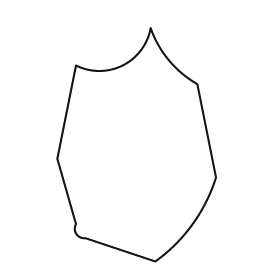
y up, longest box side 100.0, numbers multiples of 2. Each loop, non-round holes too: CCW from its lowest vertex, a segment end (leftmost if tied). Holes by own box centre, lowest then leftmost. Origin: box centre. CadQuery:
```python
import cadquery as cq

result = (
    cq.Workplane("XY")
    .moveTo(8.0, -50.0)
    .threePointArc((24.0, -34.0), (34.0, -14.0))
    .lineTo(26.0, 26.0)
    .threePointArc((14.0, 36.0), (6.0, 50.0))
    .threePointArc((-6.0, 34.0), (-26.0, 34.0))
    .lineTo(-34.0, -6.0)
    .lineTo(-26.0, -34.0)
    .threePointArc((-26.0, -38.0), (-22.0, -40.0))
    .close()
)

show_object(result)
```